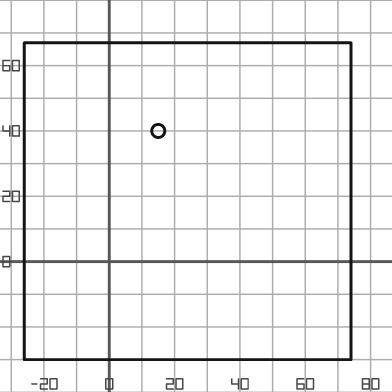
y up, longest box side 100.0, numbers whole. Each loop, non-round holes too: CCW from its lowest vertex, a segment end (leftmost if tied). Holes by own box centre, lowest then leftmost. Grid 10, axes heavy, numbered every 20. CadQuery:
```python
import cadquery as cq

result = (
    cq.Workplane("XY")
    .moveTo(-26.0, -30.0)
    .lineTo(74.0, -30.0)
    .lineTo(74.0, 67.0)
    .lineTo(-26.0, 67.0)
    .close()
    .moveTo(15.0, 40.0)
    .circle(2.0)
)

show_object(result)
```